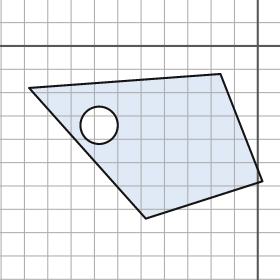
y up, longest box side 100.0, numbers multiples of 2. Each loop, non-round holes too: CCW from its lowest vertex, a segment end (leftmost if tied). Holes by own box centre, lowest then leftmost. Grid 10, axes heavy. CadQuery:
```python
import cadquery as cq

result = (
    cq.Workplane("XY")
    .moveTo(-48.0, -74.0)
    .lineTo(2.0, -58.0)
    .lineTo(-16.0, -12.0)
    .lineTo(-98.0, -18.0)
    .close()
    .moveTo(-68.0, -34.0)
    .circle(8.0)
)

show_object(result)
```